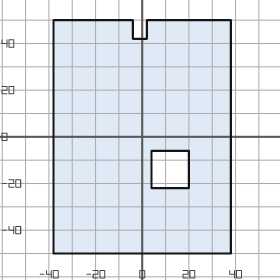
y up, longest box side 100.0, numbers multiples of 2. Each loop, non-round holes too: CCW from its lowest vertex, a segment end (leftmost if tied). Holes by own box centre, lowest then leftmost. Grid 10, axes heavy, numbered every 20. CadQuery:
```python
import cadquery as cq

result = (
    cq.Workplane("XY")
    .moveTo(-38.0, -50.0)
    .lineTo(38.0, -50.0)
    .lineTo(38.0, 50.0)
    .lineTo(2.0, 50.0)
    .lineTo(2.0, 42.0)
    .lineTo(-4.0, 42.0)
    .lineTo(-4.0, 50.0)
    .lineTo(-38.0, 50.0)
    .close()
    .moveTo(4.0, -22.0)
    .lineTo(20.0, -22.0)
    .lineTo(20.0, -6.0)
    .lineTo(4.0, -6.0)
    .close()
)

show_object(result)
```